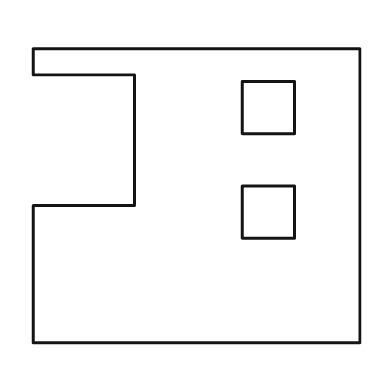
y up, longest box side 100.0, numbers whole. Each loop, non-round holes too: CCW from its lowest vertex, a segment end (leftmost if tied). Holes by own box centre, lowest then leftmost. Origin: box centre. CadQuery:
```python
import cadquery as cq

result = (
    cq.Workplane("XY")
    .moveTo(-50.0, -45.0)
    .lineTo(50.0, -45.0)
    .lineTo(50.0, 45.0)
    .lineTo(-50.0, 45.0)
    .lineTo(-50.0, 37.0)
    .lineTo(-19.0, 37.0)
    .lineTo(-19.0, -3.0)
    .lineTo(-50.0, -3.0)
    .close()
    .moveTo(14.0, -13.0)
    .lineTo(30.0, -13.0)
    .lineTo(30.0, 3.0)
    .lineTo(14.0, 3.0)
    .close()
    .moveTo(14.0, 19.0)
    .lineTo(30.0, 19.0)
    .lineTo(30.0, 35.0)
    .lineTo(14.0, 35.0)
    .close()
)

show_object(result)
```